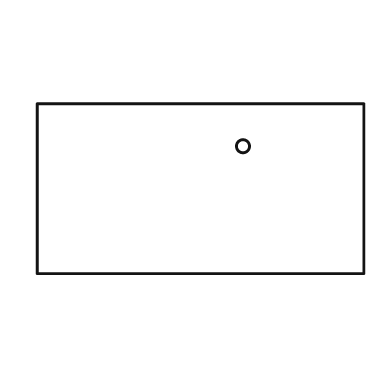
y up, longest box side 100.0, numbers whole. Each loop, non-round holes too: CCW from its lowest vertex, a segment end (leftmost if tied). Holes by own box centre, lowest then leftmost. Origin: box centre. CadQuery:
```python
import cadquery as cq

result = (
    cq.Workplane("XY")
    .moveTo(-50.0, -26.0)
    .lineTo(50.0, -26.0)
    .lineTo(50.0, 26.0)
    .lineTo(-50.0, 26.0)
    .close()
    .moveTo(13.0, 13.0)
    .circle(2.0)
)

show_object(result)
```